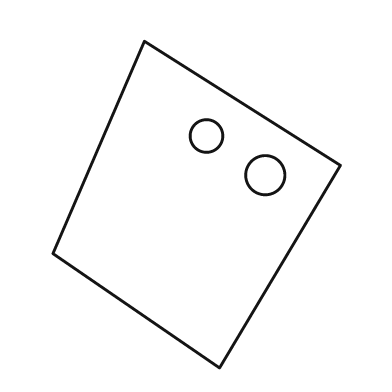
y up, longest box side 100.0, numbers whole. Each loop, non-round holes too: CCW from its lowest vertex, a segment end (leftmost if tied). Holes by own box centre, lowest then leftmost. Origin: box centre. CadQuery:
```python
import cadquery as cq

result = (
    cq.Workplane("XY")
    .moveTo(7.0, -50.0)
    .lineTo(44.0, 12.0)
    .lineTo(-16.0, 50.0)
    .lineTo(-44.0, -15.0)
    .close()
    .moveTo(21.0, 9.0)
    .circle(6.0)
    .moveTo(3.0, 21.0)
    .circle(5.0)
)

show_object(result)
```